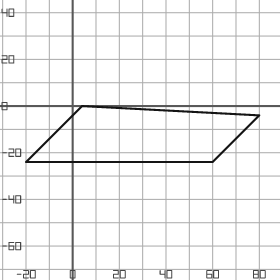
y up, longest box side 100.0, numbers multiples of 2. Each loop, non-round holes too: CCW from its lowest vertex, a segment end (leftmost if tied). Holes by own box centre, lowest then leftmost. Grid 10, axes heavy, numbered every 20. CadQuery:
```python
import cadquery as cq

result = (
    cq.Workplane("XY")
    .moveTo(-20.0, -24.0)
    .lineTo(60.0, -24.0)
    .lineTo(80.0, -4.0)
    .lineTo(4.0, 0.0)
    .close()
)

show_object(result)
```